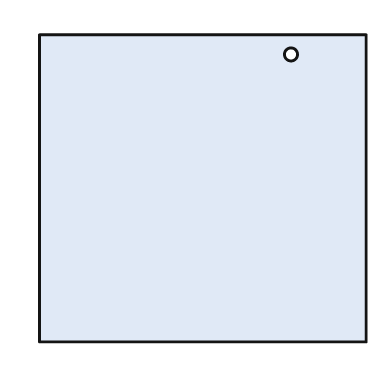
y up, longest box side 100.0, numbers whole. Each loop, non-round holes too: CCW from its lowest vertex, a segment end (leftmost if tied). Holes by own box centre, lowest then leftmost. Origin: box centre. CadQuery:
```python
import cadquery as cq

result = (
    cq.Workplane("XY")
    .moveTo(-50.0, -47.0)
    .lineTo(50.0, -47.0)
    .lineTo(50.0, 47.0)
    .lineTo(-50.0, 47.0)
    .close()
    .moveTo(27.0, 41.0)
    .circle(2.0)
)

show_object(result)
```